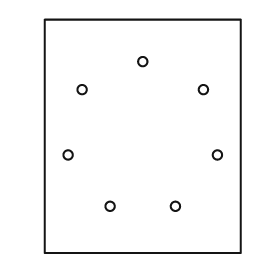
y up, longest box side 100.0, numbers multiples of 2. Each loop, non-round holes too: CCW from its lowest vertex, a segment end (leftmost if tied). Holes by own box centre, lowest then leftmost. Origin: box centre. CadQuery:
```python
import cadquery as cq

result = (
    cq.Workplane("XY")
    .moveTo(-42.0, -50.0)
    .lineTo(42.0, -50.0)
    .lineTo(42.0, 50.0)
    .lineTo(-42.0, 50.0)
    .close()
    .moveTo(-14.0, -30.0)
    .circle(2.0)
    .moveTo(14.0, -30.0)
    .circle(2.0)
    .moveTo(-32.0, -8.0)
    .circle(2.0)
    .moveTo(32.0, -8.0)
    .circle(2.0)
    .moveTo(-26.0, 20.0)
    .circle(2.0)
    .moveTo(26.0, 20.0)
    .circle(2.0)
    .moveTo(0.0, 32.0)
    .circle(2.0)
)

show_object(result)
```